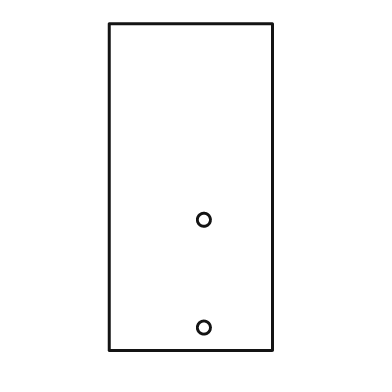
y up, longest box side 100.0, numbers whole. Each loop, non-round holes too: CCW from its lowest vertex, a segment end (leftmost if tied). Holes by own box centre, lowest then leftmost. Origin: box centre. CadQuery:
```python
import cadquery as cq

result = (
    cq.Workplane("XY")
    .moveTo(-25.0, -50.0)
    .lineTo(25.0, -50.0)
    .lineTo(25.0, 50.0)
    .lineTo(-25.0, 50.0)
    .close()
    .moveTo(4.0, -43.0)
    .circle(2.0)
    .moveTo(4.0, -10.0)
    .circle(2.0)
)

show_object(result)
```